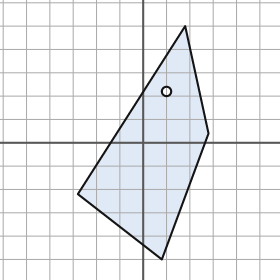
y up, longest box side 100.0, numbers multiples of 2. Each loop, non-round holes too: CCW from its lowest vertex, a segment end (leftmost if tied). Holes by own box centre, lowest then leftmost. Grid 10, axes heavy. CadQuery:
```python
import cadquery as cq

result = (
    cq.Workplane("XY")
    .moveTo(8.0, -50.0)
    .lineTo(28.0, 4.0)
    .lineTo(18.0, 50.0)
    .lineTo(-28.0, -22.0)
    .close()
    .moveTo(10.0, 22.0)
    .circle(2.0)
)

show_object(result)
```